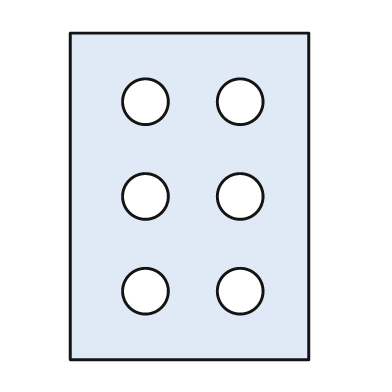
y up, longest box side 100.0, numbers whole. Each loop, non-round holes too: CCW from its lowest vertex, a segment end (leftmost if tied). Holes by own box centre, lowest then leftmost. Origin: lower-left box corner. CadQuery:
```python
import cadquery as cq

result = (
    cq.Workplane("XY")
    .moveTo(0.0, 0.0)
    .lineTo(73.0, 0.0)
    .lineTo(73.0, 100.0)
    .lineTo(0.0, 100.0)
    .close()
    .moveTo(23.0, 21.0)
    .circle(7.0)
    .moveTo(52.0, 21.0)
    .circle(7.0)
    .moveTo(23.0, 50.0)
    .circle(7.0)
    .moveTo(52.0, 50.0)
    .circle(7.0)
    .moveTo(23.0, 79.0)
    .circle(7.0)
    .moveTo(52.0, 79.0)
    .circle(7.0)
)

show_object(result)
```